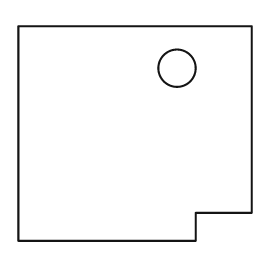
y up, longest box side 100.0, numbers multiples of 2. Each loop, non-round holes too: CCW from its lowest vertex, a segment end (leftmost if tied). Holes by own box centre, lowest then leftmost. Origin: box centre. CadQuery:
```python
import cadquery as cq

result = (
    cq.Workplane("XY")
    .moveTo(-50.0, -46.0)
    .lineTo(26.0, -46.0)
    .lineTo(26.0, -34.0)
    .lineTo(50.0, -34.0)
    .lineTo(50.0, 46.0)
    .lineTo(-50.0, 46.0)
    .close()
    .moveTo(18.0, 28.0)
    .circle(8.0)
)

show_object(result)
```